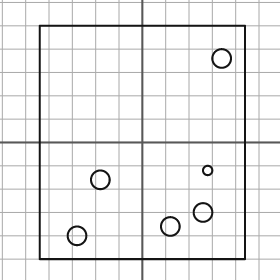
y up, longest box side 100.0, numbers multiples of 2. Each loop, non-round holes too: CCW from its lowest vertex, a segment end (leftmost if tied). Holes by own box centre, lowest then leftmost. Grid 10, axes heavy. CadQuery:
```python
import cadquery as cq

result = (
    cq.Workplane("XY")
    .moveTo(-44.0, -50.0)
    .lineTo(44.0, -50.0)
    .lineTo(44.0, 50.0)
    .lineTo(-44.0, 50.0)
    .close()
    .moveTo(-28.0, -40.0)
    .circle(4.0)
    .moveTo(12.0, -36.0)
    .circle(4.0)
    .moveTo(26.0, -30.0)
    .circle(4.0)
    .moveTo(-18.0, -16.0)
    .circle(4.0)
    .moveTo(28.0, -12.0)
    .circle(2.0)
    .moveTo(34.0, 36.0)
    .circle(4.0)
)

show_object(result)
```